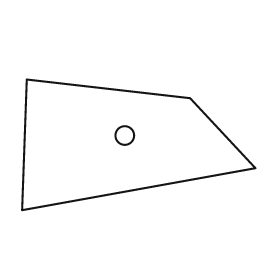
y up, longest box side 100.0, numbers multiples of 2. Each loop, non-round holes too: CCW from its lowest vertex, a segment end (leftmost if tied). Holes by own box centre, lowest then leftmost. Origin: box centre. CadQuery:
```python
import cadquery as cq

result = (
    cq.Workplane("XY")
    .moveTo(-50.0, -28.0)
    .lineTo(50.0, -10.0)
    .lineTo(22.0, 20.0)
    .lineTo(-48.0, 28.0)
    .close()
    .moveTo(-6.0, 4.0)
    .circle(4.0)
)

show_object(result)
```